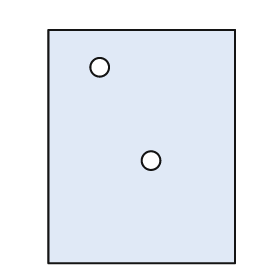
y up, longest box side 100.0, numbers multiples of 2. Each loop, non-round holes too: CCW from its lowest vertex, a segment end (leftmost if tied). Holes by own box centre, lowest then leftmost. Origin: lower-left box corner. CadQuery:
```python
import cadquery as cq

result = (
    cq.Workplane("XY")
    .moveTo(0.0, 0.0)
    .lineTo(80.0, 0.0)
    .lineTo(80.0, 100.0)
    .lineTo(0.0, 100.0)
    .close()
    .moveTo(44.0, 44.0)
    .circle(4.0)
    .moveTo(22.0, 84.0)
    .circle(4.0)
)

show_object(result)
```